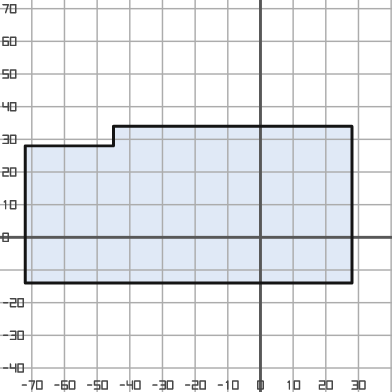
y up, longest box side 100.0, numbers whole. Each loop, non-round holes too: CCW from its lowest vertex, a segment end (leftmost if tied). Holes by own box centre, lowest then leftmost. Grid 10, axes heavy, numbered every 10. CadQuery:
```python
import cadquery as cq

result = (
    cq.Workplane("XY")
    .moveTo(-72.0, -14.0)
    .lineTo(28.0, -14.0)
    .lineTo(28.0, 34.0)
    .lineTo(-45.0, 34.0)
    .lineTo(-45.0, 28.0)
    .lineTo(-72.0, 28.0)
    .close()
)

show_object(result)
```